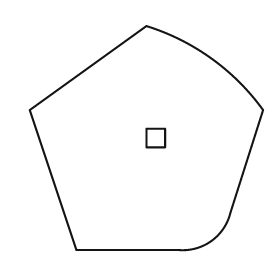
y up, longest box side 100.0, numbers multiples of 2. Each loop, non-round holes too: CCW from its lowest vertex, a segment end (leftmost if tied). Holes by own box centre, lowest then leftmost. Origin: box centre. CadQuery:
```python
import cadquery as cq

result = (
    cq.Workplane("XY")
    .moveTo(-30.0, -48.0)
    .lineTo(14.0, -48.0)
    .threePointArc((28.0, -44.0), (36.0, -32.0))
    .lineTo(50.0, 12.0)
    .threePointArc((28.0, 34.0), (0.0, 48.0))
    .lineTo(-50.0, 12.0)
    .close()
    .moveTo(0.0, -4.0)
    .lineTo(8.0, -4.0)
    .lineTo(8.0, 4.0)
    .lineTo(0.0, 4.0)
    .close()
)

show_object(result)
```